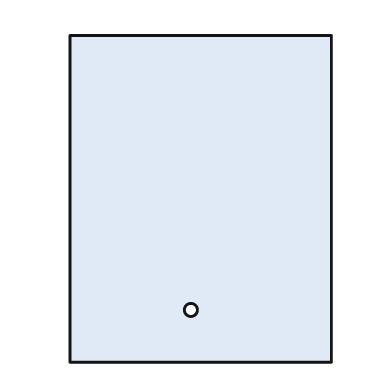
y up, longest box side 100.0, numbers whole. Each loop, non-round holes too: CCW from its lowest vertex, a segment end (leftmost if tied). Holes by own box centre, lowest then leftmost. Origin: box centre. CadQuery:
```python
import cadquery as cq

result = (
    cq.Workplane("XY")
    .moveTo(-40.0, -50.0)
    .lineTo(40.0, -50.0)
    .lineTo(40.0, 50.0)
    .lineTo(-40.0, 50.0)
    .close()
    .moveTo(-3.0, -34.0)
    .circle(2.0)
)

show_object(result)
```